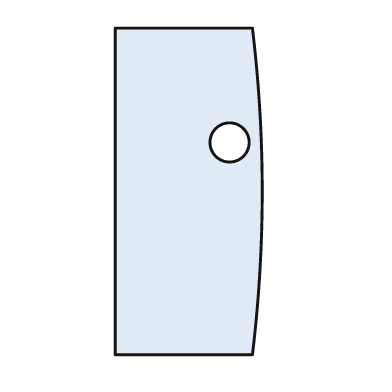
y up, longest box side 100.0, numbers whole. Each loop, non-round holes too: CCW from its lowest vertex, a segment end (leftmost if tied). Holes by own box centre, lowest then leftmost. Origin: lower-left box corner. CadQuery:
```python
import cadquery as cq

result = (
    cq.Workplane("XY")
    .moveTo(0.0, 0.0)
    .lineTo(42.0, 0.0)
    .threePointArc((45.0, 50.0), (42.0, 100.0))
    .lineTo(0.0, 100.0)
    .close()
    .moveTo(35.0, 65.0)
    .circle(6.0)
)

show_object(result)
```